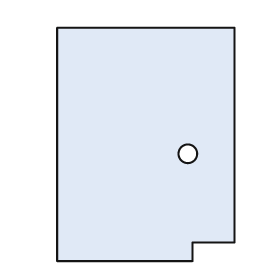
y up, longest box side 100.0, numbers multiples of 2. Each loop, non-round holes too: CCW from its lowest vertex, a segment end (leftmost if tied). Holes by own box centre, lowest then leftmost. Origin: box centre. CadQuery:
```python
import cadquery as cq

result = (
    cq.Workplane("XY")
    .moveTo(-38.0, -50.0)
    .lineTo(20.0, -50.0)
    .lineTo(20.0, -42.0)
    .lineTo(38.0, -42.0)
    .lineTo(38.0, 50.0)
    .lineTo(-38.0, 50.0)
    .close()
    .moveTo(18.0, -4.0)
    .circle(4.0)
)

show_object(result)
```